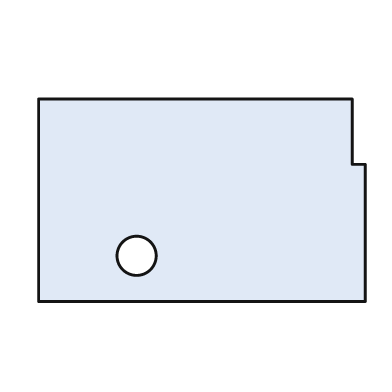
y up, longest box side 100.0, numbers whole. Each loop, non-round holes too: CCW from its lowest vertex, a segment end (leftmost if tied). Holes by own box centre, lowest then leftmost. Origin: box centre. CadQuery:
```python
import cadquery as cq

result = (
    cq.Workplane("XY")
    .moveTo(-50.0, -31.0)
    .lineTo(50.0, -31.0)
    .lineTo(50.0, 11.0)
    .lineTo(46.0, 11.0)
    .lineTo(46.0, 31.0)
    .lineTo(-50.0, 31.0)
    .close()
    .moveTo(-20.0, -17.0)
    .circle(6.0)
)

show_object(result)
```